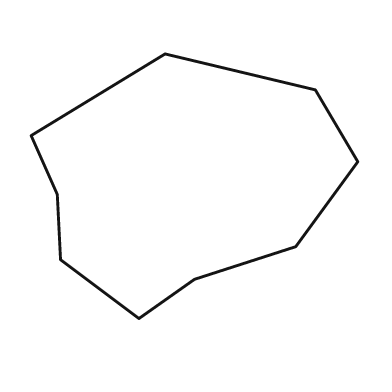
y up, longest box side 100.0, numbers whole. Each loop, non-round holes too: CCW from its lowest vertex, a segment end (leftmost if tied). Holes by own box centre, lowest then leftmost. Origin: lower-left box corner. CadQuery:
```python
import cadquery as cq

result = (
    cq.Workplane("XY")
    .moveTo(33.0, 0.0)
    .lineTo(50.0, 12.0)
    .lineTo(81.0, 22.0)
    .lineTo(100.0, 48.0)
    .lineTo(87.0, 70.0)
    .lineTo(41.0, 81.0)
    .lineTo(0.0, 56.0)
    .lineTo(8.0, 38.0)
    .lineTo(9.0, 18.0)
    .close()
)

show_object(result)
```